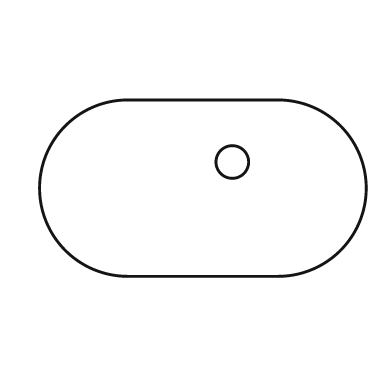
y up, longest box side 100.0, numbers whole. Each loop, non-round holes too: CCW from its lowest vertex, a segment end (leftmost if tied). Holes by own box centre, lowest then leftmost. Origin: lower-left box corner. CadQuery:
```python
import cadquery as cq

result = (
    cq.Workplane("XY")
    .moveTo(27.0, 0.0)
    .lineTo(73.0, 0.0)
    .threePointArc((100.0, 27.0), (73.0, 54.0))
    .lineTo(27.0, 54.0)
    .threePointArc((0.0, 27.0), (27.0, 0.0))
    .close()
    .moveTo(59.0, 35.0)
    .circle(5.0)
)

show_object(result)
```